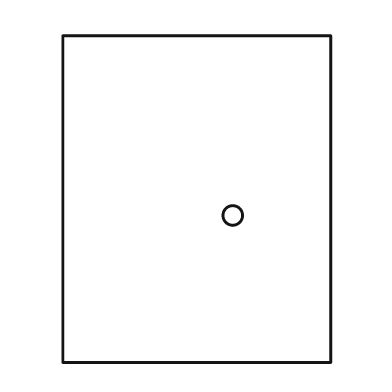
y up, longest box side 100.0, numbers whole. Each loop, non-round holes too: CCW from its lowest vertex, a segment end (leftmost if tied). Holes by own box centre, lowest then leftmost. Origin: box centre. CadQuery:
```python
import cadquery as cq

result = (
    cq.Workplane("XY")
    .moveTo(-41.0, -50.0)
    .lineTo(41.0, -50.0)
    .lineTo(41.0, 50.0)
    .lineTo(-41.0, 50.0)
    .close()
    .moveTo(11.0, -5.0)
    .circle(3.0)
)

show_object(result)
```